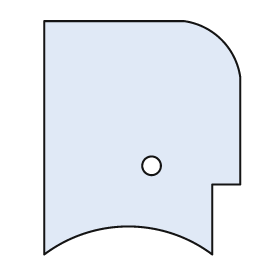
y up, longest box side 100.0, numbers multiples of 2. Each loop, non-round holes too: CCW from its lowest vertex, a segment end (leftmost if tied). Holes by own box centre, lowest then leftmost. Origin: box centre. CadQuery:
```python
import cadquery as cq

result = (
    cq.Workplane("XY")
    .moveTo(-42.0, -50.0)
    .threePointArc((-6.0, -38.0), (30.0, -50.0))
    .lineTo(30.0, -20.0)
    .lineTo(42.0, -20.0)
    .lineTo(42.0, 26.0)
    .threePointArc((34.0, 42.0), (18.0, 50.0))
    .lineTo(-42.0, 50.0)
    .close()
    .moveTo(4.0, -12.0)
    .circle(4.0)
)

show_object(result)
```